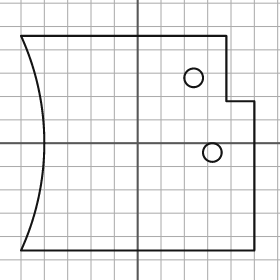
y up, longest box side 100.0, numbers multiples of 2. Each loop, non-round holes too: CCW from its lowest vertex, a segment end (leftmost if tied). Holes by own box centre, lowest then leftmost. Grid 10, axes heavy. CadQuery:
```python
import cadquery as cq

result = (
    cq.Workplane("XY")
    .moveTo(-50.0, -46.0)
    .lineTo(50.0, -46.0)
    .lineTo(50.0, 18.0)
    .lineTo(38.0, 18.0)
    .lineTo(38.0, 46.0)
    .lineTo(-50.0, 46.0)
    .threePointArc((-40.0, 0.0), (-50.0, -46.0))
    .close()
    .moveTo(32.0, -4.0)
    .circle(4.0)
    .moveTo(24.0, 28.0)
    .circle(4.0)
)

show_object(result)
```